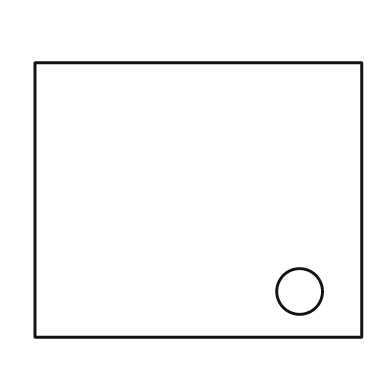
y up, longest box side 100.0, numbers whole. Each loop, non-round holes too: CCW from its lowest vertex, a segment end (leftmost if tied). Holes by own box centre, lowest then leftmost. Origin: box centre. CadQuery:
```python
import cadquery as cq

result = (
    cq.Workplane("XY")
    .moveTo(-50.0, -42.0)
    .lineTo(50.0, -42.0)
    .lineTo(50.0, 42.0)
    .lineTo(-50.0, 42.0)
    .close()
    .moveTo(31.0, -28.0)
    .circle(7.0)
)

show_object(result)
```